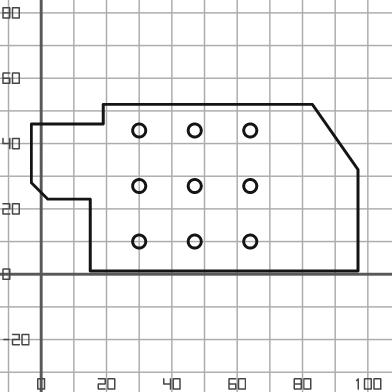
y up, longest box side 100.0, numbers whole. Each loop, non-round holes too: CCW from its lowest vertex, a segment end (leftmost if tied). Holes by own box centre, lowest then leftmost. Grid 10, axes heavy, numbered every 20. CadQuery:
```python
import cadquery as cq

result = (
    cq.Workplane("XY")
    .moveTo(15.0, 1.0)
    .lineTo(97.0, 1.0)
    .lineTo(97.0, 32.0)
    .lineTo(83.0, 52.0)
    .lineTo(19.0, 52.0)
    .lineTo(19.0, 46.0)
    .lineTo(-3.0, 46.0)
    .lineTo(-3.0, 28.0)
    .lineTo(2.0, 23.0)
    .lineTo(15.0, 23.0)
    .close()
    .moveTo(30.0, 10.0)
    .circle(2.0)
    .moveTo(47.0, 10.0)
    .circle(2.0)
    .moveTo(64.0, 10.0)
    .circle(2.0)
    .moveTo(30.0, 27.0)
    .circle(2.0)
    .moveTo(47.0, 27.0)
    .circle(2.0)
    .moveTo(64.0, 27.0)
    .circle(2.0)
    .moveTo(30.0, 44.0)
    .circle(2.0)
    .moveTo(47.0, 44.0)
    .circle(2.0)
    .moveTo(64.0, 44.0)
    .circle(2.0)
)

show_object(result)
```